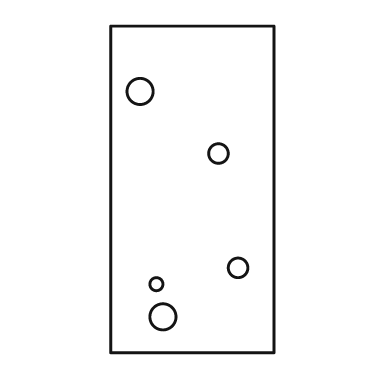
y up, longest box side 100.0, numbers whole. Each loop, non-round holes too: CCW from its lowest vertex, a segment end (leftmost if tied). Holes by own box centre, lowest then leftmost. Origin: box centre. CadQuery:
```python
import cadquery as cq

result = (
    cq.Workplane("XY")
    .moveTo(-25.0, -50.0)
    .lineTo(25.0, -50.0)
    .lineTo(25.0, 50.0)
    .lineTo(-25.0, 50.0)
    .close()
    .moveTo(-9.0, -39.0)
    .circle(4.0)
    .moveTo(-11.0, -29.0)
    .circle(2.0)
    .moveTo(14.0, -24.0)
    .circle(3.0)
    .moveTo(8.0, 11.0)
    .circle(3.0)
    .moveTo(-16.0, 30.0)
    .circle(4.0)
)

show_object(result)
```